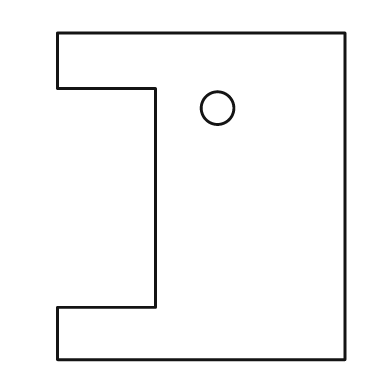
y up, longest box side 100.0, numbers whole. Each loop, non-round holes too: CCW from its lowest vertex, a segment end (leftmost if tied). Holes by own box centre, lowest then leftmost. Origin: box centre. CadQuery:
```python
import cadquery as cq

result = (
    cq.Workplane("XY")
    .moveTo(-44.0, -50.0)
    .lineTo(44.0, -50.0)
    .lineTo(44.0, 50.0)
    .lineTo(-44.0, 50.0)
    .lineTo(-44.0, 33.0)
    .lineTo(-14.0, 33.0)
    .lineTo(-14.0, -34.0)
    .lineTo(-44.0, -34.0)
    .close()
    .moveTo(5.0, 27.0)
    .circle(5.0)
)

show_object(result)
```